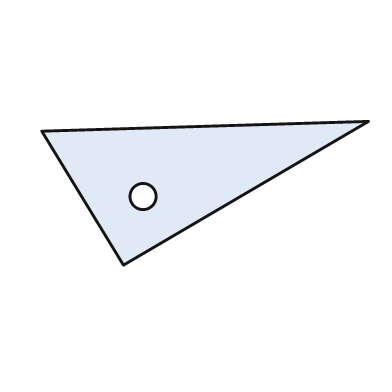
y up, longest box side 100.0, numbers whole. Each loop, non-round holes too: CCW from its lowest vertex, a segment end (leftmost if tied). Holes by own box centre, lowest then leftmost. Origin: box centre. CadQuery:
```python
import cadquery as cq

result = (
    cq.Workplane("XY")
    .moveTo(-25.0, -22.0)
    .lineTo(50.0, 22.0)
    .lineTo(-50.0, 19.0)
    .close()
    .moveTo(-19.0, -1.0)
    .circle(4.0)
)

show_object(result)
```